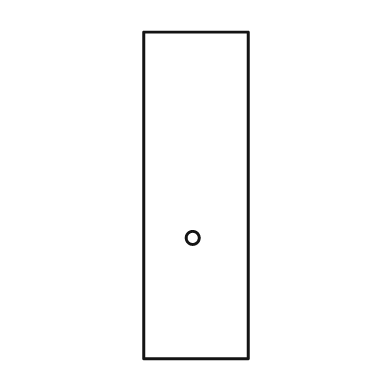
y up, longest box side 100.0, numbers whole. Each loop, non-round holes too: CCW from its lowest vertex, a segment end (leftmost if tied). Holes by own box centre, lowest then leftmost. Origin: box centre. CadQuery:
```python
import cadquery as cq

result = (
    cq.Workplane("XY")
    .moveTo(-16.0, -50.0)
    .lineTo(16.0, -50.0)
    .lineTo(16.0, 50.0)
    .lineTo(-16.0, 50.0)
    .close()
    .moveTo(-1.0, -13.0)
    .circle(2.0)
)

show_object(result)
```